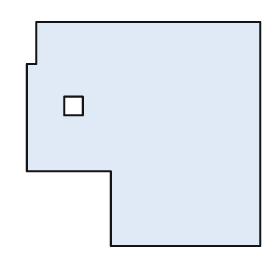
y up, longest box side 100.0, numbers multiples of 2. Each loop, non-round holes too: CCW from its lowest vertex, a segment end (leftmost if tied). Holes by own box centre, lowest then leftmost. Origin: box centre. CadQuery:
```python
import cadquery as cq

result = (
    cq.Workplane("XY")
    .moveTo(-14.0, -48.0)
    .lineTo(50.0, -48.0)
    .lineTo(50.0, 48.0)
    .lineTo(-46.0, 48.0)
    .lineTo(-46.0, 30.0)
    .lineTo(-50.0, 30.0)
    .lineTo(-50.0, -16.0)
    .lineTo(-14.0, -16.0)
    .close()
    .moveTo(-34.0, 8.0)
    .lineTo(-26.0, 8.0)
    .lineTo(-26.0, 16.0)
    .lineTo(-34.0, 16.0)
    .close()
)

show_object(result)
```